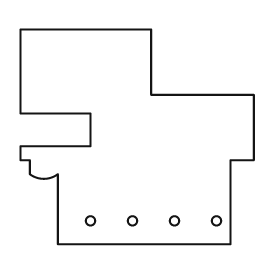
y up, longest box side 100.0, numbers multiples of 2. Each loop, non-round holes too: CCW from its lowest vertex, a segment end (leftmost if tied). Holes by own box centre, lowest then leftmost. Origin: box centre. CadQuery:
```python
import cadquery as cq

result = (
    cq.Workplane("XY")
    .moveTo(-34.0, -46.0)
    .lineTo(40.0, -46.0)
    .lineTo(40.0, -10.0)
    .lineTo(50.0, -10.0)
    .lineTo(50.0, 18.0)
    .lineTo(6.0, 18.0)
    .lineTo(6.0, 46.0)
    .lineTo(-50.0, 46.0)
    .lineTo(-50.0, 10.0)
    .lineTo(-20.0, 10.0)
    .lineTo(-20.0, -4.0)
    .lineTo(-50.0, -4.0)
    .lineTo(-50.0, -10.0)
    .lineTo(-46.0, -10.0)
    .lineTo(-46.0, -16.0)
    .threePointArc((-40.0, -18.0), (-34.0, -16.0))
    .close()
    .moveTo(-20.0, -36.0)
    .circle(2.0)
    .moveTo(-2.0, -36.0)
    .circle(2.0)
    .moveTo(16.0, -36.0)
    .circle(2.0)
    .moveTo(34.0, -36.0)
    .circle(2.0)
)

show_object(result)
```